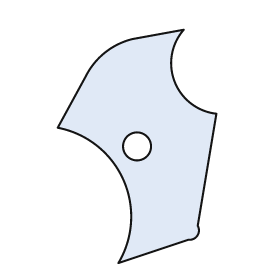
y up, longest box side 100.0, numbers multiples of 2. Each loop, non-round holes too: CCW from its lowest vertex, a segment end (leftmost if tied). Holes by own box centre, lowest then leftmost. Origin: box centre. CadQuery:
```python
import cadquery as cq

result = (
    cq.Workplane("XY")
    .moveTo(-8.0, -50.0)
    .lineTo(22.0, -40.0)
    .threePointArc((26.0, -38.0), (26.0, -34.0))
    .lineTo(34.0, 14.0)
    .threePointArc((16.0, 28.0), (20.0, 50.0))
    .lineTo(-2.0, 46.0)
    .threePointArc((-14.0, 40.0), (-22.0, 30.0))
    .lineTo(-34.0, 8.0)
    .threePointArc((-6.0, -14.0), (-8.0, -50.0))
    .close()
    .moveTo(0.0, 0.0)
    .circle(6.0)
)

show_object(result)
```